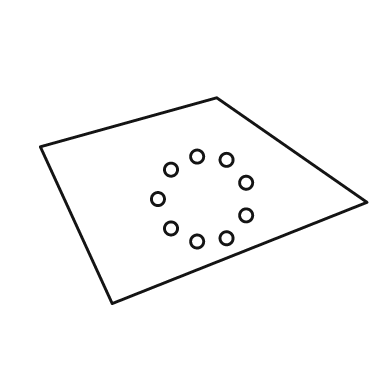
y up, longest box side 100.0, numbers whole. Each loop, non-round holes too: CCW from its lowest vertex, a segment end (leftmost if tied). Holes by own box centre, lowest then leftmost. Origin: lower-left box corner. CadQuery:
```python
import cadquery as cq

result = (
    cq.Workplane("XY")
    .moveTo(22.0, 0.0)
    .lineTo(100.0, 31.0)
    .lineTo(54.0, 63.0)
    .lineTo(0.0, 48.0)
    .close()
    .moveTo(48.0, 19.0)
    .circle(2.0)
    .moveTo(57.0, 20.0)
    .circle(2.0)
    .moveTo(40.0, 23.0)
    .circle(2.0)
    .moveTo(63.0, 27.0)
    .circle(2.0)
    .moveTo(36.0, 32.0)
    .circle(2.0)
    .moveTo(63.0, 37.0)
    .circle(2.0)
    .moveTo(40.0, 41.0)
    .circle(2.0)
    .moveTo(57.0, 44.0)
    .circle(2.0)
    .moveTo(48.0, 45.0)
    .circle(2.0)
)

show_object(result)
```